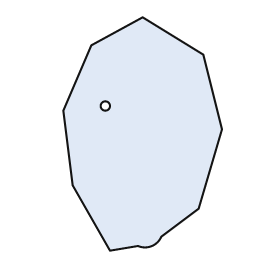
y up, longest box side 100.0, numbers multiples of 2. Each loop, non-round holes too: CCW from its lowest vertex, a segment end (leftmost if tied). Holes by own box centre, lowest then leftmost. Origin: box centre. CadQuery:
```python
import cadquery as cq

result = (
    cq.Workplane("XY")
    .moveTo(-14.0, -50.0)
    .lineTo(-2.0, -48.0)
    .threePointArc((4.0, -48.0), (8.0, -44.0))
    .lineTo(24.0, -32.0)
    .lineTo(34.0, 2.0)
    .lineTo(26.0, 34.0)
    .lineTo(0.0, 50.0)
    .lineTo(-22.0, 38.0)
    .lineTo(-34.0, 10.0)
    .lineTo(-30.0, -22.0)
    .close()
    .moveTo(-16.0, 12.0)
    .circle(2.0)
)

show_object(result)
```